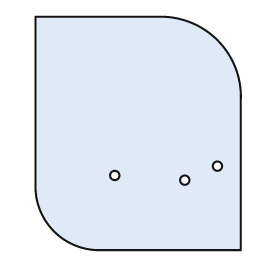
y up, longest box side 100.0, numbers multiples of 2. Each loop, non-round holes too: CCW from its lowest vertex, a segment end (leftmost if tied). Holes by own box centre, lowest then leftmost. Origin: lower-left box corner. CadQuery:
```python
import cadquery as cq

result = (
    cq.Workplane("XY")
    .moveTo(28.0, 0.0)
    .lineTo(88.0, 0.0)
    .lineTo(88.0, 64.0)
    .threePointArc((78.0, 90.0), (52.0, 100.0))
    .lineTo(0.0, 100.0)
    .lineTo(0.0, 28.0)
    .threePointArc((8.0, 8.0), (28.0, 0.0))
    .close()
    .moveTo(64.0, 30.0)
    .circle(2.0)
    .moveTo(34.0, 32.0)
    .circle(2.0)
    .moveTo(78.0, 36.0)
    .circle(2.0)
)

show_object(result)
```